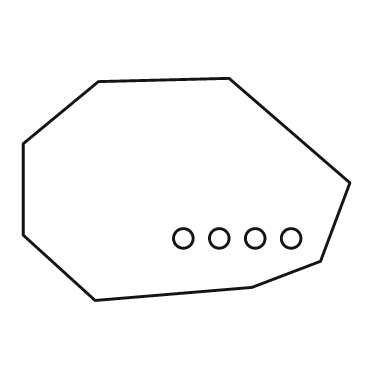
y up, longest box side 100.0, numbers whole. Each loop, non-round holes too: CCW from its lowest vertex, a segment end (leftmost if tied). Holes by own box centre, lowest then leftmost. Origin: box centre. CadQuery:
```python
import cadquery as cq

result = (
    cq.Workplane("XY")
    .moveTo(-28.0, -34.0)
    .lineTo(20.0, -30.0)
    .lineTo(41.0, -22.0)
    .lineTo(50.0, 2.0)
    .lineTo(13.0, 34.0)
    .lineTo(-27.0, 33.0)
    .lineTo(-50.0, 14.0)
    .lineTo(-50.0, -14.0)
    .close()
    .moveTo(-1.0, -15.0)
    .circle(3.0)
    .moveTo(10.0, -15.0)
    .circle(3.0)
    .moveTo(21.0, -15.0)
    .circle(3.0)
    .moveTo(32.0, -15.0)
    .circle(3.0)
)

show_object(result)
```